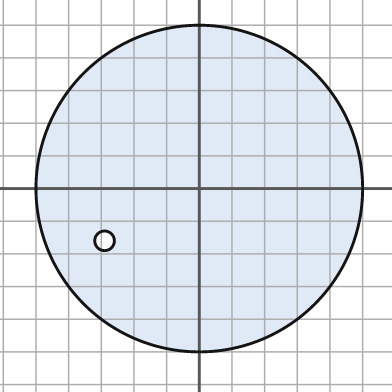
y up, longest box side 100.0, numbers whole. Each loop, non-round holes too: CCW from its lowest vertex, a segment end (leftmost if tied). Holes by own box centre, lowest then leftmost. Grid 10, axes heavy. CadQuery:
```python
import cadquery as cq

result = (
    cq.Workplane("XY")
    .moveTo(0.0, 0.0)
    .circle(50.0)
    .moveTo(-29.0, -16.0)
    .circle(3.0)
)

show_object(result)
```